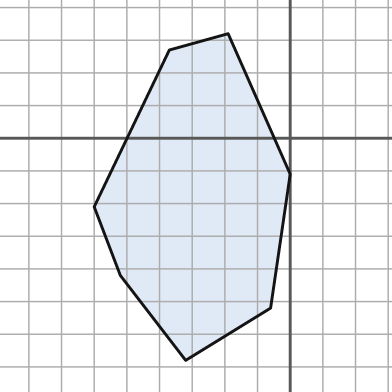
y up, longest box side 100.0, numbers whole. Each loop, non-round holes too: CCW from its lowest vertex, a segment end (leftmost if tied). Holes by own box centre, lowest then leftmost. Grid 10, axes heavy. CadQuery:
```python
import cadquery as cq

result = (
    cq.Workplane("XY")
    .moveTo(-32.0, -68.0)
    .lineTo(-6.0, -52.0)
    .lineTo(0.0, -11.0)
    .lineTo(-19.0, 32.0)
    .lineTo(-37.0, 27.0)
    .lineTo(-60.0, -21.0)
    .lineTo(-52.0, -42.0)
    .close()
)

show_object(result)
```